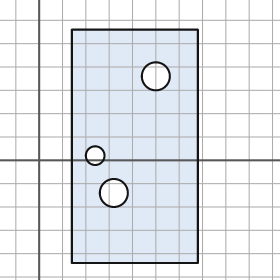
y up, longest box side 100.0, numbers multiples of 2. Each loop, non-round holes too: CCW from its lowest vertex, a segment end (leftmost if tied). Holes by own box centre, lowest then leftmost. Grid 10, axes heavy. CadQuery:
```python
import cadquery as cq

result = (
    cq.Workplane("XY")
    .moveTo(14.0, -44.0)
    .lineTo(68.0, -44.0)
    .lineTo(68.0, 56.0)
    .lineTo(14.0, 56.0)
    .close()
    .moveTo(32.0, -14.0)
    .circle(6.0)
    .moveTo(24.0, 2.0)
    .circle(4.0)
    .moveTo(50.0, 36.0)
    .circle(6.0)
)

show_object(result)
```